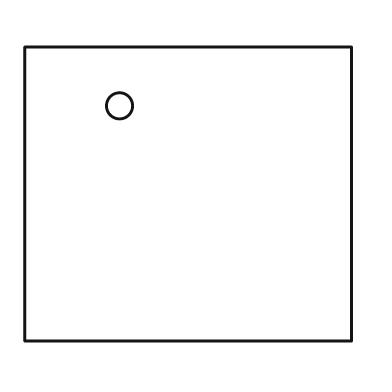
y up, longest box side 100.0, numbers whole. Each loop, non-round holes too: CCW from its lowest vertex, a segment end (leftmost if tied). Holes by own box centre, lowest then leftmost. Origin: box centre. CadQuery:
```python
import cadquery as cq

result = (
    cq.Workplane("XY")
    .moveTo(-50.0, -45.0)
    .lineTo(50.0, -45.0)
    .lineTo(50.0, 45.0)
    .lineTo(-50.0, 45.0)
    .close()
    .moveTo(-21.0, 27.0)
    .circle(4.0)
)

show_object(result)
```